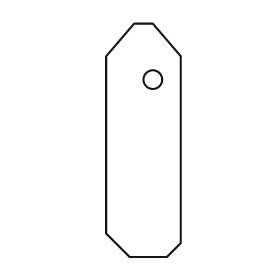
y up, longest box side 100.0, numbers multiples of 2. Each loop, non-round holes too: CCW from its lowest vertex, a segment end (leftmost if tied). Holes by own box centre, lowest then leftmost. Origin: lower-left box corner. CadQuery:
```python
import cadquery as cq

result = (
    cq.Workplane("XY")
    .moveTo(10.0, 0.0)
    .lineTo(26.0, 0.0)
    .lineTo(32.0, 6.0)
    .lineTo(32.0, 86.0)
    .lineTo(20.0, 100.0)
    .lineTo(12.0, 100.0)
    .lineTo(0.0, 86.0)
    .lineTo(0.0, 10.0)
    .close()
    .moveTo(20.0, 76.0)
    .circle(4.0)
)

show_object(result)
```